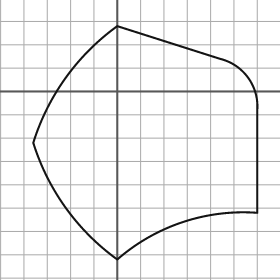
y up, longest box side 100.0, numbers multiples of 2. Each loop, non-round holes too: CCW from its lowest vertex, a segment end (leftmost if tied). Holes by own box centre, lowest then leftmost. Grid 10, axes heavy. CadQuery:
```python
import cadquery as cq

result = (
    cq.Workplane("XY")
    .moveTo(0.0, -72.0)
    .threePointArc((28.0, -56.0), (60.0, -52.0))
    .lineTo(60.0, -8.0)
    .threePointArc((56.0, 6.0), (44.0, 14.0))
    .lineTo(0.0, 28.0)
    .threePointArc((-22.0, 6.0), (-36.0, -22.0))
    .threePointArc((-22.0, -50.0), (0.0, -72.0))
    .close()
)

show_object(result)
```